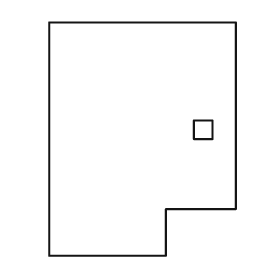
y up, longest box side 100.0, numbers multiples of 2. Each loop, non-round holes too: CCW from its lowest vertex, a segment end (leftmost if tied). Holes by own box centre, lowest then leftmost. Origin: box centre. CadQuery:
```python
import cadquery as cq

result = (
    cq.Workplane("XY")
    .moveTo(-40.0, -50.0)
    .lineTo(10.0, -50.0)
    .lineTo(10.0, -30.0)
    .lineTo(40.0, -30.0)
    .lineTo(40.0, 50.0)
    .lineTo(-40.0, 50.0)
    .close()
    .moveTo(22.0, 0.0)
    .lineTo(30.0, 0.0)
    .lineTo(30.0, 8.0)
    .lineTo(22.0, 8.0)
    .close()
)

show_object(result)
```